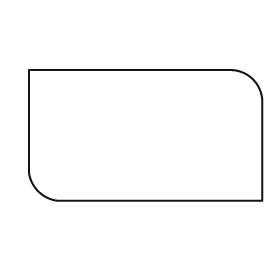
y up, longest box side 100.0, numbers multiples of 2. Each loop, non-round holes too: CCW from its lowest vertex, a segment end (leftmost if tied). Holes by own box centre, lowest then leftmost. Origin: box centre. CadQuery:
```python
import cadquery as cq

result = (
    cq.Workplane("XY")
    .moveTo(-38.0, -28.0)
    .lineTo(50.0, -28.0)
    .lineTo(50.0, 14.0)
    .threePointArc((46.0, 24.0), (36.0, 28.0))
    .lineTo(-50.0, 28.0)
    .lineTo(-50.0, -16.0)
    .threePointArc((-46.0, -24.0), (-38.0, -28.0))
    .close()
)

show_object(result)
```